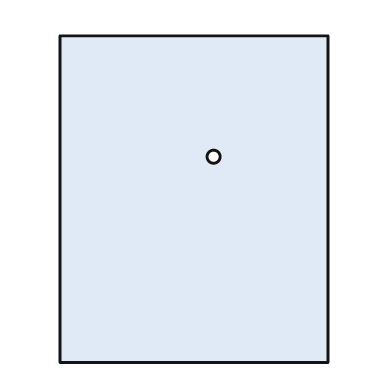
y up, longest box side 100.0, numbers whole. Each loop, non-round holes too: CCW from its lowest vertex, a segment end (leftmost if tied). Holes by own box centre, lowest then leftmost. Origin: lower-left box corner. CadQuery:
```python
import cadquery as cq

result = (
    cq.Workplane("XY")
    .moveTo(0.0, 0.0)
    .lineTo(82.0, 0.0)
    .lineTo(82.0, 100.0)
    .lineTo(0.0, 100.0)
    .close()
    .moveTo(47.0, 63.0)
    .circle(2.0)
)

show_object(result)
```